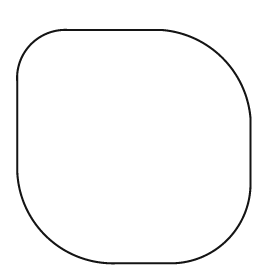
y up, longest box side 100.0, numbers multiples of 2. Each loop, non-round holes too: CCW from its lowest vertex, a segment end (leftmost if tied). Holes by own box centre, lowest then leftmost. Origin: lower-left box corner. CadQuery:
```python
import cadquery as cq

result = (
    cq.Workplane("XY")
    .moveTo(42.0, 0.0)
    .lineTo(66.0, 0.0)
    .threePointArc((90.0, 10.0), (100.0, 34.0))
    .lineTo(100.0, 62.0)
    .threePointArc((88.0, 88.0), (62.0, 100.0))
    .lineTo(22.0, 100.0)
    .threePointArc((6.0, 94.0), (0.0, 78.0))
    .lineTo(0.0, 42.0)
    .threePointArc((12.0, 12.0), (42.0, 0.0))
    .close()
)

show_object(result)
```